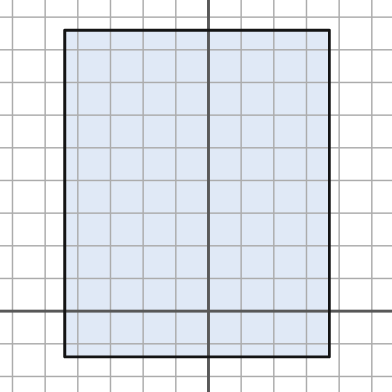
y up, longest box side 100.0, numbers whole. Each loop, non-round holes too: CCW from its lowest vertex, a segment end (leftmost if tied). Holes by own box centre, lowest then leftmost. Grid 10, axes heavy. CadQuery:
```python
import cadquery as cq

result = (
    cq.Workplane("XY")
    .moveTo(-44.0, -14.0)
    .lineTo(37.0, -14.0)
    .lineTo(37.0, 86.0)
    .lineTo(-44.0, 86.0)
    .close()
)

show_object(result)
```